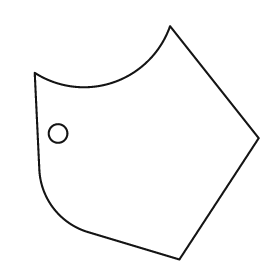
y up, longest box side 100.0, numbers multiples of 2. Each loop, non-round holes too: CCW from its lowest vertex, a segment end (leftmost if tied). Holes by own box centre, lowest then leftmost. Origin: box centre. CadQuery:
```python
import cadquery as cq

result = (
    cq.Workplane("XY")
    .moveTo(14.0, -50.0)
    .lineTo(48.0, 2.0)
    .lineTo(10.0, 50.0)
    .threePointArc((-14.0, 26.0), (-48.0, 30.0))
    .lineTo(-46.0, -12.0)
    .threePointArc((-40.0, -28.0), (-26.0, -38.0))
    .close()
    .moveTo(-38.0, 4.0)
    .circle(4.0)
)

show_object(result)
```